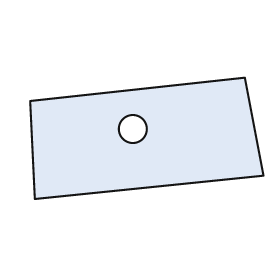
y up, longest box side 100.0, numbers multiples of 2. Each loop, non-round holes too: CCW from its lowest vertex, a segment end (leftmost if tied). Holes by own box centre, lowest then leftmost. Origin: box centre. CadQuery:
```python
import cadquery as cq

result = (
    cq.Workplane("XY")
    .moveTo(-48.0, -26.0)
    .lineTo(50.0, -16.0)
    .lineTo(42.0, 26.0)
    .lineTo(-50.0, 16.0)
    .close()
    .moveTo(-6.0, 4.0)
    .circle(6.0)
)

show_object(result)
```